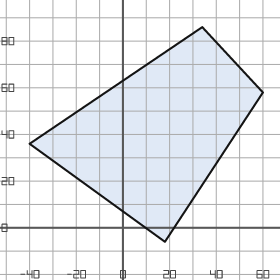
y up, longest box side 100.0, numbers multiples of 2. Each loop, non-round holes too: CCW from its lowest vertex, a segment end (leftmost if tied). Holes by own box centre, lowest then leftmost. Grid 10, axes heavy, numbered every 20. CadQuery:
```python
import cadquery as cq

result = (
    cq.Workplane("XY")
    .moveTo(18.0, -6.0)
    .lineTo(60.0, 58.0)
    .lineTo(34.0, 86.0)
    .lineTo(-40.0, 36.0)
    .close()
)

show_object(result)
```